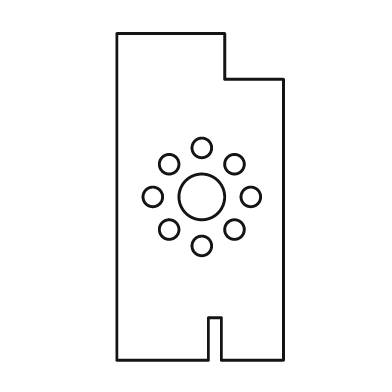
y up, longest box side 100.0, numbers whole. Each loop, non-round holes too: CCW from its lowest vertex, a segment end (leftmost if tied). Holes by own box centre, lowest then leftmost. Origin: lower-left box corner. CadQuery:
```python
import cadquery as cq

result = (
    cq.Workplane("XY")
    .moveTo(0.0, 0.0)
    .lineTo(28.0, 0.0)
    .lineTo(28.0, 13.0)
    .lineTo(32.0, 13.0)
    .lineTo(32.0, 0.0)
    .lineTo(51.0, 0.0)
    .lineTo(51.0, 86.0)
    .lineTo(33.0, 86.0)
    .lineTo(33.0, 100.0)
    .lineTo(0.0, 100.0)
    .close()
    .moveTo(26.0, 35.0)
    .circle(3.0)
    .moveTo(16.0, 40.0)
    .circle(3.0)
    .moveTo(36.0, 40.0)
    .circle(3.0)
    .moveTo(11.0, 50.0)
    .circle(3.0)
    .moveTo(26.0, 50.0)
    .circle(7.0)
    .moveTo(41.0, 50.0)
    .circle(3.0)
    .moveTo(16.0, 60.0)
    .circle(3.0)
    .moveTo(36.0, 60.0)
    .circle(3.0)
    .moveTo(26.0, 65.0)
    .circle(3.0)
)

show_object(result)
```